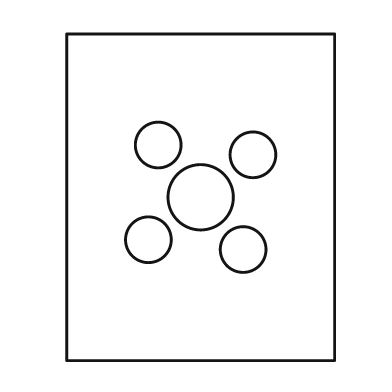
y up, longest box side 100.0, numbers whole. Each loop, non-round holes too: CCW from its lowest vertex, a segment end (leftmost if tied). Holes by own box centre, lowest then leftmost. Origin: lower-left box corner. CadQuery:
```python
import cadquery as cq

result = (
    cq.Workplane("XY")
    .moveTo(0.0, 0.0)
    .lineTo(82.0, 0.0)
    .lineTo(82.0, 100.0)
    .lineTo(0.0, 100.0)
    .close()
    .moveTo(54.0, 34.0)
    .circle(7.0)
    .moveTo(25.0, 37.0)
    .circle(7.0)
    .moveTo(41.0, 50.0)
    .circle(10.0)
    .moveTo(57.0, 63.0)
    .circle(7.0)
    .moveTo(28.0, 66.0)
    .circle(7.0)
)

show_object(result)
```